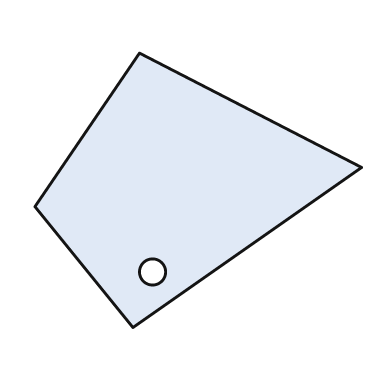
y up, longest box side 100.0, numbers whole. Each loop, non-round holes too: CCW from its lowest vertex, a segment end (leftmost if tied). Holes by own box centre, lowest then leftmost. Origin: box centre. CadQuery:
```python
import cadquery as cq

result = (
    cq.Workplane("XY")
    .moveTo(-20.0, -42.0)
    .lineTo(50.0, 7.0)
    .lineTo(-18.0, 42.0)
    .lineTo(-50.0, -5.0)
    .close()
    .moveTo(-14.0, -25.0)
    .circle(4.0)
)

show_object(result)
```